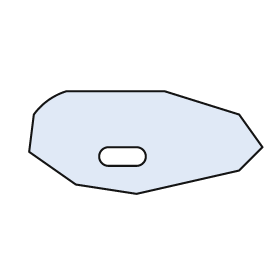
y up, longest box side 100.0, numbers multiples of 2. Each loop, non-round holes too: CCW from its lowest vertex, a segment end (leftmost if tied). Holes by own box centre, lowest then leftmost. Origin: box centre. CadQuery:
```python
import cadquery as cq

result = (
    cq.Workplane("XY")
    .moveTo(-4.0, -22.0)
    .lineTo(40.0, -12.0)
    .lineTo(50.0, -2.0)
    .lineTo(40.0, 12.0)
    .lineTo(8.0, 22.0)
    .lineTo(-34.0, 22.0)
    .threePointArc((-42.0, 18.0), (-48.0, 12.0))
    .lineTo(-50.0, -4.0)
    .lineTo(-30.0, -18.0)
    .close()
    .moveTo(-16.0, -10.0)
    .lineTo(-4.0, -10.0)
    .threePointArc((0.0, -6.0), (-4.0, -2.0))
    .lineTo(-16.0, -2.0)
    .threePointArc((-20.0, -6.0), (-16.0, -10.0))
    .close()
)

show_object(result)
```